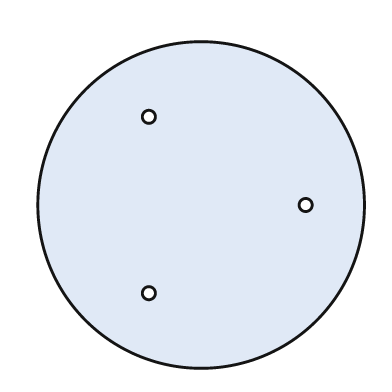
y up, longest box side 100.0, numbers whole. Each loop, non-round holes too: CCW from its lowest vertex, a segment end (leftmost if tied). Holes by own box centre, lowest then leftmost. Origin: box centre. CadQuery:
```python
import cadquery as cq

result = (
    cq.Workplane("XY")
    .moveTo(0.0, 0.0)
    .circle(50.0)
    .moveTo(-16.0, -27.0)
    .circle(2.0)
    .moveTo(32.0, 0.0)
    .circle(2.0)
    .moveTo(-16.0, 27.0)
    .circle(2.0)
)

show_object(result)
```